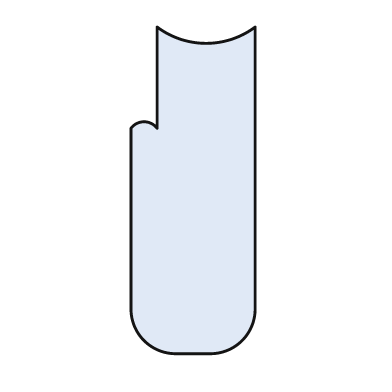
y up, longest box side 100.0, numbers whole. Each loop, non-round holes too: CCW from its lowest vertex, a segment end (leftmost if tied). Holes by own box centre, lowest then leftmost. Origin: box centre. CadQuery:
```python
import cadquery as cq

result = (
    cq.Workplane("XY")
    .moveTo(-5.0, -50.0)
    .lineTo(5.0, -50.0)
    .threePointArc((15.0, -46.0), (19.0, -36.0))
    .lineTo(19.0, 50.0)
    .threePointArc((4.0, 45.0), (-11.0, 50.0))
    .lineTo(-11.0, 19.0)
    .threePointArc((-15.0, 21.0), (-19.0, 19.0))
    .lineTo(-19.0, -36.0)
    .threePointArc((-15.0, -46.0), (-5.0, -50.0))
    .close()
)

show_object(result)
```